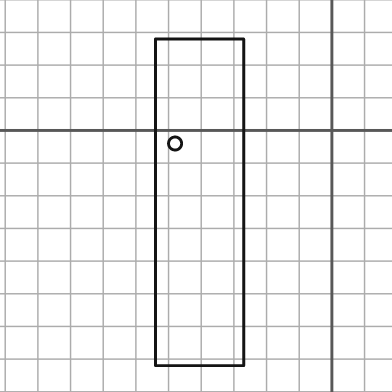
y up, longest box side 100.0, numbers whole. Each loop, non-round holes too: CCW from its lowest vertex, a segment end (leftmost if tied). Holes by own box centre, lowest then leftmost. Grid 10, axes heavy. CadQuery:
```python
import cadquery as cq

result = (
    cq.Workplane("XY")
    .moveTo(-54.0, -72.0)
    .lineTo(-27.0, -72.0)
    .lineTo(-27.0, 28.0)
    .lineTo(-54.0, 28.0)
    .close()
    .moveTo(-48.0, -4.0)
    .circle(2.0)
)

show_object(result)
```